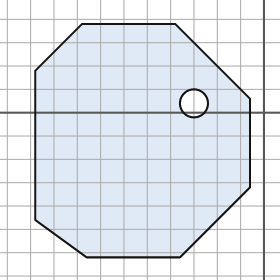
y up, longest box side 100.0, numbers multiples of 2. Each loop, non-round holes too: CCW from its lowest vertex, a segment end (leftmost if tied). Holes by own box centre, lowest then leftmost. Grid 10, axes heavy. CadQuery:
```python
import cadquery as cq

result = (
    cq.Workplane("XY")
    .moveTo(-76.0, -62.0)
    .lineTo(-36.0, -62.0)
    .lineTo(-6.0, -32.0)
    .lineTo(-6.0, 6.0)
    .lineTo(-38.0, 38.0)
    .lineTo(-78.0, 38.0)
    .lineTo(-98.0, 18.0)
    .lineTo(-98.0, -46.0)
    .close()
    .moveTo(-30.0, 4.0)
    .circle(6.0)
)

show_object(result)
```